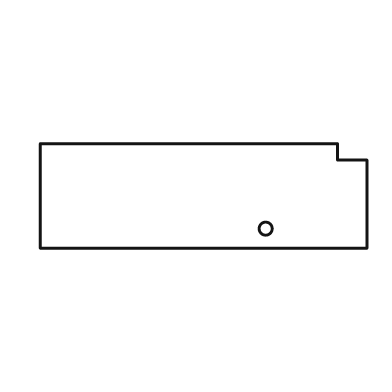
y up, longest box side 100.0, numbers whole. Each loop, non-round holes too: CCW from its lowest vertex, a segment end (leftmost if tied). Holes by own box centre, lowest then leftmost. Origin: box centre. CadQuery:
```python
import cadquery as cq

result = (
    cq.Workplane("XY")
    .moveTo(-50.0, -16.0)
    .lineTo(50.0, -16.0)
    .lineTo(50.0, 11.0)
    .lineTo(41.0, 11.0)
    .lineTo(41.0, 16.0)
    .lineTo(-50.0, 16.0)
    .close()
    .moveTo(19.0, -10.0)
    .circle(2.0)
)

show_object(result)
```